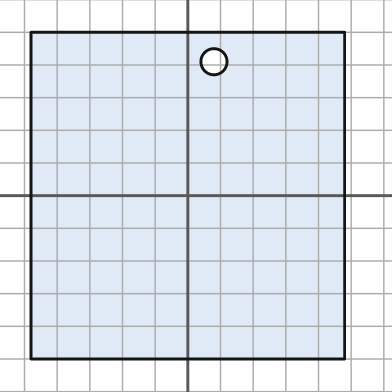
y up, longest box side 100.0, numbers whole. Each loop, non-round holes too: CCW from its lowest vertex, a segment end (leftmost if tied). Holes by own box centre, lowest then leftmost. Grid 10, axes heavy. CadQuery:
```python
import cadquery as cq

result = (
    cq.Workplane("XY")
    .moveTo(-48.0, -50.0)
    .lineTo(48.0, -50.0)
    .lineTo(48.0, 50.0)
    .lineTo(-48.0, 50.0)
    .close()
    .moveTo(8.0, 41.0)
    .circle(4.0)
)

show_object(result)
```